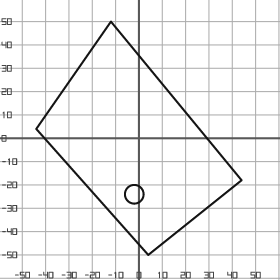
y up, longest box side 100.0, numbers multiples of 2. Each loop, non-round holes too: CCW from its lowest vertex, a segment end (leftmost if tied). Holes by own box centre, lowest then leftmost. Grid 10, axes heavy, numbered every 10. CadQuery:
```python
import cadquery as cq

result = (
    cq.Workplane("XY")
    .moveTo(4.0, -50.0)
    .lineTo(44.0, -18.0)
    .lineTo(-12.0, 50.0)
    .lineTo(-44.0, 4.0)
    .close()
    .moveTo(-2.0, -24.0)
    .circle(4.0)
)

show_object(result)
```